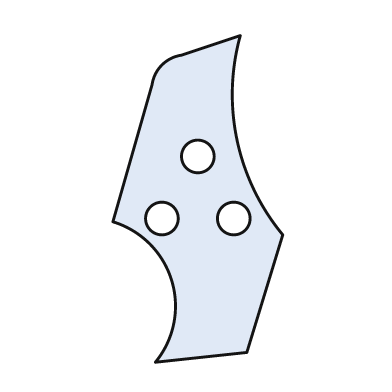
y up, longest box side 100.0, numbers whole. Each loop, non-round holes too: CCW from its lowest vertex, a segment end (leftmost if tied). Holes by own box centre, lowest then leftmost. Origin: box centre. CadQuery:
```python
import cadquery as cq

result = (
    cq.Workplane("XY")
    .moveTo(-13.0, -50.0)
    .lineTo(15.0, -47.0)
    .lineTo(26.0, -11.0)
    .threePointArc((12.0, 18.0), (13.0, 50.0))
    .lineTo(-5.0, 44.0)
    .threePointArc((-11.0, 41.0), (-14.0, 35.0))
    .lineTo(-26.0, -7.0)
    .threePointArc((-8.0, -25.0), (-13.0, -50.0))
    .close()
    .moveTo(-11.0, -6.0)
    .circle(5.0)
    .moveTo(11.0, -6.0)
    .circle(5.0)
    .moveTo(0.0, 13.0)
    .circle(5.0)
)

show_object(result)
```